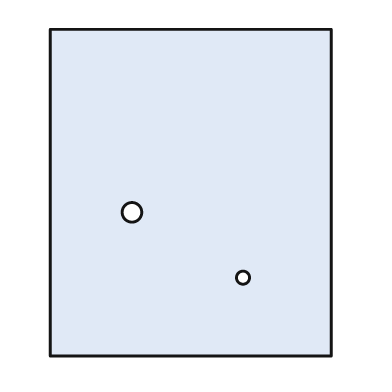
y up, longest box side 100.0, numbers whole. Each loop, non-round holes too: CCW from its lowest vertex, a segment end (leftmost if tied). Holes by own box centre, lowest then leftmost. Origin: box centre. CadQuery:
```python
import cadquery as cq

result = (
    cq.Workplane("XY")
    .moveTo(-43.0, -50.0)
    .lineTo(43.0, -50.0)
    .lineTo(43.0, 50.0)
    .lineTo(-43.0, 50.0)
    .close()
    .moveTo(16.0, -26.0)
    .circle(2.0)
    .moveTo(-18.0, -6.0)
    .circle(3.0)
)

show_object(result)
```